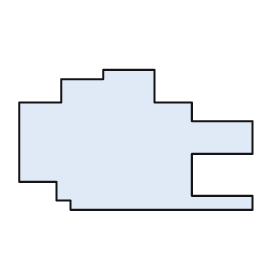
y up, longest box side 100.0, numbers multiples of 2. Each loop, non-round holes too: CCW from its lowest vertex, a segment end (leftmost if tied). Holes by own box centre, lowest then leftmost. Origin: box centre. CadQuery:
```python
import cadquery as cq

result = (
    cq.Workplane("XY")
    .moveTo(-28.0, -30.0)
    .lineTo(50.0, -30.0)
    .lineTo(50.0, -24.0)
    .lineTo(24.0, -24.0)
    .lineTo(24.0, -6.0)
    .lineTo(50.0, -6.0)
    .lineTo(50.0, 8.0)
    .lineTo(24.0, 8.0)
    .lineTo(24.0, 16.0)
    .lineTo(8.0, 16.0)
    .lineTo(8.0, 30.0)
    .lineTo(-14.0, 30.0)
    .lineTo(-14.0, 26.0)
    .lineTo(-32.0, 26.0)
    .lineTo(-32.0, 16.0)
    .lineTo(-50.0, 16.0)
    .lineTo(-50.0, -18.0)
    .lineTo(-34.0, -18.0)
    .lineTo(-34.0, -26.0)
    .lineTo(-28.0, -26.0)
    .close()
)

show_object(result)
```